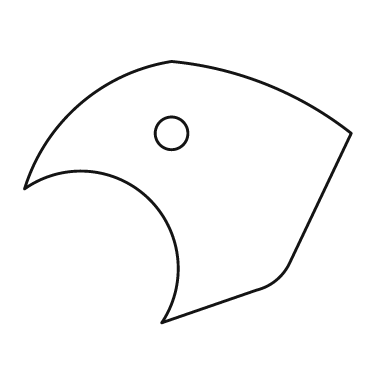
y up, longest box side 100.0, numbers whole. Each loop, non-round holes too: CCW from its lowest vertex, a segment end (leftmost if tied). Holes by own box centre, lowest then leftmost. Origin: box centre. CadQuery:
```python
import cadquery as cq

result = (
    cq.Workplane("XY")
    .moveTo(-8.0, -40.0)
    .lineTo(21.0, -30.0)
    .threePointArc((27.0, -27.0), (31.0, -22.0))
    .lineTo(50.0, 18.0)
    .threePointArc((24.0, 33.0), (-5.0, 40.0))
    .threePointArc((-33.0, 27.0), (-50.0, 1.0))
    .threePointArc((-12.0, -2.0), (-8.0, -40.0))
    .close()
    .moveTo(-5.0, 18.0)
    .circle(5.0)
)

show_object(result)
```